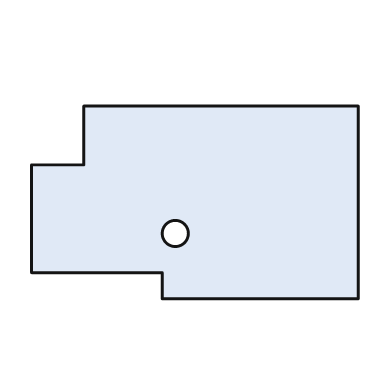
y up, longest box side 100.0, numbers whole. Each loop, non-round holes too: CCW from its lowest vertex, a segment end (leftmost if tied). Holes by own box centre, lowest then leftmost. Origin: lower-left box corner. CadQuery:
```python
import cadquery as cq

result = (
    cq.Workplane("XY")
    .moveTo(40.0, 0.0)
    .lineTo(100.0, 0.0)
    .lineTo(100.0, 59.0)
    .lineTo(16.0, 59.0)
    .lineTo(16.0, 41.0)
    .lineTo(0.0, 41.0)
    .lineTo(0.0, 8.0)
    .lineTo(40.0, 8.0)
    .close()
    .moveTo(44.0, 20.0)
    .circle(4.0)
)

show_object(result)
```